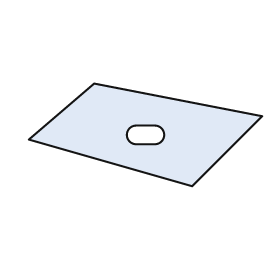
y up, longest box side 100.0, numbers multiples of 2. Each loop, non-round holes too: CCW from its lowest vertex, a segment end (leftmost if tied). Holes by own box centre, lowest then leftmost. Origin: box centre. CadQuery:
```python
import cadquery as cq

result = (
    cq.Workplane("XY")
    .moveTo(20.0, -22.0)
    .lineTo(50.0, 8.0)
    .lineTo(-22.0, 22.0)
    .lineTo(-50.0, -2.0)
    .close()
    .moveTo(-4.0, -4.0)
    .lineTo(4.0, -4.0)
    .threePointArc((8.0, 0.0), (4.0, 4.0))
    .lineTo(-4.0, 4.0)
    .threePointArc((-8.0, 0.0), (-4.0, -4.0))
    .close()
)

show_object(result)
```